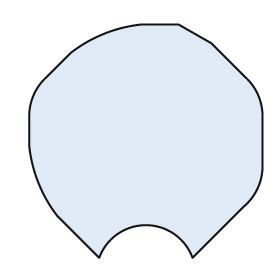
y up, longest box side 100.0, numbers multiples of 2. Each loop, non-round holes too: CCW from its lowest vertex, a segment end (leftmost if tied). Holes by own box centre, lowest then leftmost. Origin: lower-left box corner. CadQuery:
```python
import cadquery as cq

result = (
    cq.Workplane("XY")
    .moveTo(30.0, 0.0)
    .threePointArc((50.0, 14.0), (70.0, 0.0))
    .lineTo(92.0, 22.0)
    .threePointArc((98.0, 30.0), (100.0, 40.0))
    .lineTo(100.0, 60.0)
    .threePointArc((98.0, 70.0), (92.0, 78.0))
    .lineTo(78.0, 92.0)
    .lineTo(64.0, 100.0)
    .lineTo(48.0, 100.0)
    .threePointArc((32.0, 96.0), (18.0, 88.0))
    .lineTo(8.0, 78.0)
    .threePointArc((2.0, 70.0), (0.0, 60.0))
    .lineTo(0.0, 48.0)
    .threePointArc((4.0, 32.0), (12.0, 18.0))
    .close()
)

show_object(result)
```